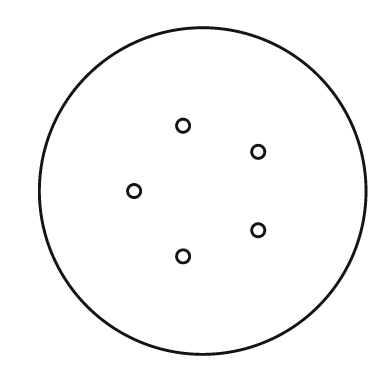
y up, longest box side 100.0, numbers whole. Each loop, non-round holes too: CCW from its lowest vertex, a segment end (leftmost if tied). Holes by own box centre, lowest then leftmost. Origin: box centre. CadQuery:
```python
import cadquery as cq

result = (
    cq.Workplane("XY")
    .moveTo(0.0, 0.0)
    .circle(50.0)
    .moveTo(-6.0, -20.0)
    .circle(2.0)
    .moveTo(17.0, -12.0)
    .circle(2.0)
    .moveTo(-21.0, 0.0)
    .circle(2.0)
    .moveTo(17.0, 12.0)
    .circle(2.0)
    .moveTo(-6.0, 20.0)
    .circle(2.0)
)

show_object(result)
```